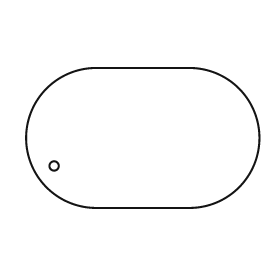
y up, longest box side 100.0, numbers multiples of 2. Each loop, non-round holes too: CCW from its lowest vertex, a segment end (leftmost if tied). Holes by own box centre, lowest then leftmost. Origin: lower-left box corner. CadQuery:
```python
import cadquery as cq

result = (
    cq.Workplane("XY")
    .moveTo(30.0, 0.0)
    .lineTo(70.0, 0.0)
    .threePointArc((100.0, 30.0), (70.0, 60.0))
    .lineTo(30.0, 60.0)
    .threePointArc((0.0, 30.0), (30.0, 0.0))
    .close()
    .moveTo(12.0, 18.0)
    .circle(2.0)
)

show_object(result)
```